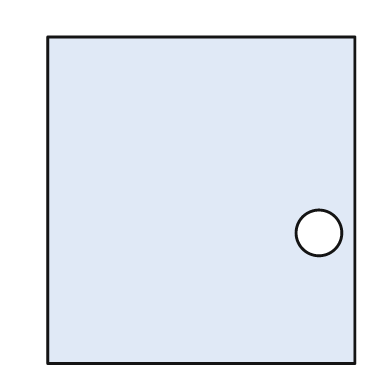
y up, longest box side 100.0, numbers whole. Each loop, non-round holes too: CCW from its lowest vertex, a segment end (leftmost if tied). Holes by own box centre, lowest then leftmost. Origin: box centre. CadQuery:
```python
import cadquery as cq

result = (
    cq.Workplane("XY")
    .moveTo(-47.0, -50.0)
    .lineTo(47.0, -50.0)
    .lineTo(47.0, 50.0)
    .lineTo(-47.0, 50.0)
    .close()
    .moveTo(36.0, -10.0)
    .circle(7.0)
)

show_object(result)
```